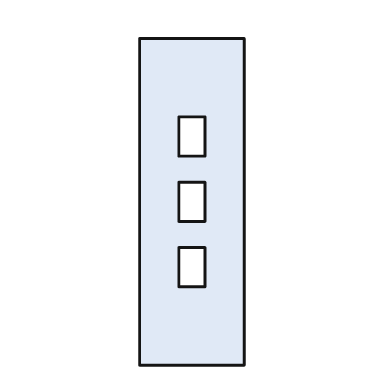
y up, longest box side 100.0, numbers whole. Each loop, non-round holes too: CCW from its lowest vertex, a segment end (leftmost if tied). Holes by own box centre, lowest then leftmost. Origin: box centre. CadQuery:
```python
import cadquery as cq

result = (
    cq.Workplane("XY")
    .moveTo(-16.0, -50.0)
    .lineTo(16.0, -50.0)
    .lineTo(16.0, 50.0)
    .lineTo(-16.0, 50.0)
    .close()
    .moveTo(-4.0, -26.0)
    .lineTo(4.0, -26.0)
    .lineTo(4.0, -14.0)
    .lineTo(-4.0, -14.0)
    .close()
    .moveTo(-4.0, -6.0)
    .lineTo(4.0, -6.0)
    .lineTo(4.0, 6.0)
    .lineTo(-4.0, 6.0)
    .close()
    .moveTo(-4.0, 14.0)
    .lineTo(4.0, 14.0)
    .lineTo(4.0, 26.0)
    .lineTo(-4.0, 26.0)
    .close()
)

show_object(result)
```